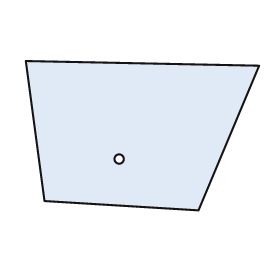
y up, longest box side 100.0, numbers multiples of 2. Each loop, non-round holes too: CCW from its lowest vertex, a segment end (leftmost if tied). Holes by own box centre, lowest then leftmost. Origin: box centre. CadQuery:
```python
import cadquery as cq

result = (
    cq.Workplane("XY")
    .moveTo(24.0, -32.0)
    .lineTo(50.0, 30.0)
    .lineTo(-50.0, 32.0)
    .lineTo(-42.0, -28.0)
    .close()
    .moveTo(-10.0, -10.0)
    .circle(2.0)
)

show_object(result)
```